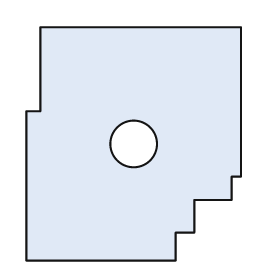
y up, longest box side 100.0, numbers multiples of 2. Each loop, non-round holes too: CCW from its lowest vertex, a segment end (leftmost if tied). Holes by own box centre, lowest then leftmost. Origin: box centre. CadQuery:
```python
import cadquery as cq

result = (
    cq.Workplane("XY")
    .moveTo(-46.0, -50.0)
    .lineTo(18.0, -50.0)
    .lineTo(18.0, -38.0)
    .lineTo(26.0, -38.0)
    .lineTo(26.0, -24.0)
    .lineTo(42.0, -24.0)
    .lineTo(42.0, -14.0)
    .lineTo(46.0, -14.0)
    .lineTo(46.0, 50.0)
    .lineTo(-40.0, 50.0)
    .lineTo(-40.0, 14.0)
    .lineTo(-46.0, 14.0)
    .close()
    .moveTo(0.0, 0.0)
    .circle(10.0)
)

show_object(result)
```